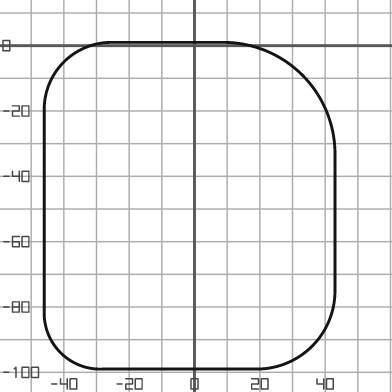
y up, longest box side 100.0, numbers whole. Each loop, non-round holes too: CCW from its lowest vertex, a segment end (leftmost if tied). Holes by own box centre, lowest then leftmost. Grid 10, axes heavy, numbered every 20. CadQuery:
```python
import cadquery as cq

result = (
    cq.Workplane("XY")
    .moveTo(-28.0, -99.0)
    .lineTo(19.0, -99.0)
    .threePointArc((36.0, -92.0), (43.0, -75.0))
    .lineTo(43.0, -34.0)
    .threePointArc((33.0, -9.0), (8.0, 1.0))
    .lineTo(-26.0, 1.0)
    .threePointArc((-40.0, -5.0), (-46.0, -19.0))
    .lineTo(-46.0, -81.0)
    .threePointArc((-41.0, -94.0), (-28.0, -99.0))
    .close()
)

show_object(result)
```